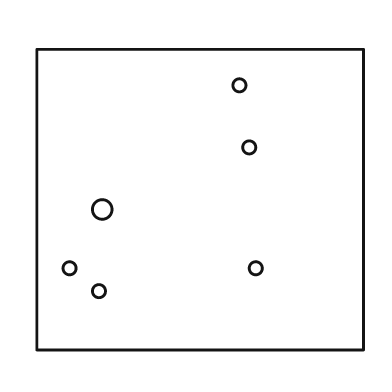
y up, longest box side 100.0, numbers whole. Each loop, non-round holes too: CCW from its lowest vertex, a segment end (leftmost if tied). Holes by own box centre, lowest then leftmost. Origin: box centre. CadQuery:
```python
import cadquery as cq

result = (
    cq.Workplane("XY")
    .moveTo(-50.0, -46.0)
    .lineTo(50.0, -46.0)
    .lineTo(50.0, 46.0)
    .lineTo(-50.0, 46.0)
    .close()
    .moveTo(-31.0, -28.0)
    .circle(2.0)
    .moveTo(-40.0, -21.0)
    .circle(2.0)
    .moveTo(17.0, -21.0)
    .circle(2.0)
    .moveTo(-30.0, -3.0)
    .circle(3.0)
    .moveTo(15.0, 16.0)
    .circle(2.0)
    .moveTo(12.0, 35.0)
    .circle(2.0)
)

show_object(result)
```